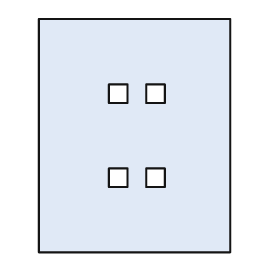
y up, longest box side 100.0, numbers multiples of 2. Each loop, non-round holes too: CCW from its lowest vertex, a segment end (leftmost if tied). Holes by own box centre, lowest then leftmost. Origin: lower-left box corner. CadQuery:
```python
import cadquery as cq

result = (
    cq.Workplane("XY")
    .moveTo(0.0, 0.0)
    .lineTo(82.0, 0.0)
    .lineTo(82.0, 100.0)
    .lineTo(0.0, 100.0)
    .close()
    .moveTo(30.0, 28.0)
    .lineTo(38.0, 28.0)
    .lineTo(38.0, 36.0)
    .lineTo(30.0, 36.0)
    .close()
    .moveTo(46.0, 28.0)
    .lineTo(54.0, 28.0)
    .lineTo(54.0, 36.0)
    .lineTo(46.0, 36.0)
    .close()
    .moveTo(30.0, 64.0)
    .lineTo(38.0, 64.0)
    .lineTo(38.0, 72.0)
    .lineTo(30.0, 72.0)
    .close()
    .moveTo(46.0, 64.0)
    .lineTo(54.0, 64.0)
    .lineTo(54.0, 72.0)
    .lineTo(46.0, 72.0)
    .close()
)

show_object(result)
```